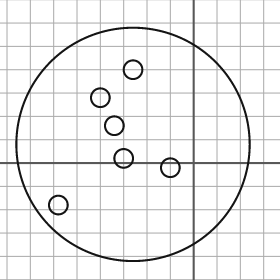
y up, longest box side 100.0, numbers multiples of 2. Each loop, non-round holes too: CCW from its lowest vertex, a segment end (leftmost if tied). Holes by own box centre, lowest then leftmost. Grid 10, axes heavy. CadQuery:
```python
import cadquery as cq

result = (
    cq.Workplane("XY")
    .moveTo(-26.0, 8.0)
    .circle(50.0)
    .moveTo(-58.0, -18.0)
    .circle(4.0)
    .moveTo(-10.0, -2.0)
    .circle(4.0)
    .moveTo(-30.0, 2.0)
    .circle(4.0)
    .moveTo(-34.0, 16.0)
    .circle(4.0)
    .moveTo(-40.0, 28.0)
    .circle(4.0)
    .moveTo(-26.0, 40.0)
    .circle(4.0)
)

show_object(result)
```